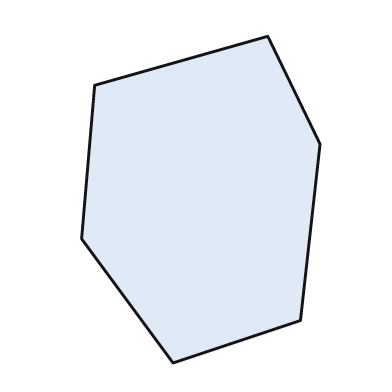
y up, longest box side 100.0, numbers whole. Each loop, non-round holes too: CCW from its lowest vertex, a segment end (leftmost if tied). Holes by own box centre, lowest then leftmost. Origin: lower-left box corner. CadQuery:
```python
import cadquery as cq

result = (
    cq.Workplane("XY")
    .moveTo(28.0, 0.0)
    .lineTo(67.0, 13.0)
    .lineTo(73.0, 67.0)
    .lineTo(57.0, 100.0)
    .lineTo(4.0, 85.0)
    .lineTo(0.0, 38.0)
    .close()
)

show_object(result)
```